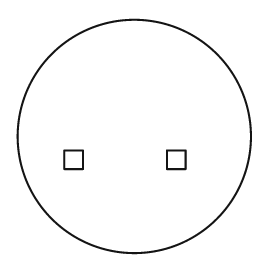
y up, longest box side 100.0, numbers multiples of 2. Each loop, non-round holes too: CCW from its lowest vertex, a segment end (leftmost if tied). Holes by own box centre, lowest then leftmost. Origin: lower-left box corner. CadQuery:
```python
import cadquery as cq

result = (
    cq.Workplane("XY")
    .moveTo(50.0, 50.0)
    .circle(50.0)
    .moveTo(20.0, 36.0)
    .lineTo(28.0, 36.0)
    .lineTo(28.0, 44.0)
    .lineTo(20.0, 44.0)
    .close()
    .moveTo(64.0, 36.0)
    .lineTo(72.0, 36.0)
    .lineTo(72.0, 44.0)
    .lineTo(64.0, 44.0)
    .close()
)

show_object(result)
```